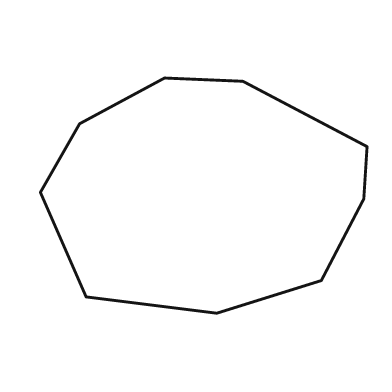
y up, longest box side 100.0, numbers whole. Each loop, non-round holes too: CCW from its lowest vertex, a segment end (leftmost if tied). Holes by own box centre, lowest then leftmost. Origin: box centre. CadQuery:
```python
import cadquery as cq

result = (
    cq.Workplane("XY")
    .moveTo(4.0, -36.0)
    .lineTo(36.0, -26.0)
    .lineTo(49.0, -1.0)
    .lineTo(50.0, 15.0)
    .lineTo(12.0, 35.0)
    .lineTo(-12.0, 36.0)
    .lineTo(-38.0, 22.0)
    .lineTo(-50.0, 1.0)
    .lineTo(-36.0, -31.0)
    .close()
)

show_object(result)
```